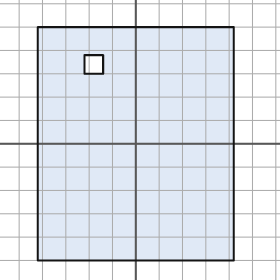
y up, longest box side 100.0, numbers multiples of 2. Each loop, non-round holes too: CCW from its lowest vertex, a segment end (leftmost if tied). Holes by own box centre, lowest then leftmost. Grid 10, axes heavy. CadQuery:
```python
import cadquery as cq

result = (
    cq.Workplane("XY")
    .moveTo(-42.0, -50.0)
    .lineTo(42.0, -50.0)
    .lineTo(42.0, 50.0)
    .lineTo(-42.0, 50.0)
    .close()
    .moveTo(-22.0, 30.0)
    .lineTo(-14.0, 30.0)
    .lineTo(-14.0, 38.0)
    .lineTo(-22.0, 38.0)
    .close()
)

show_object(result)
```